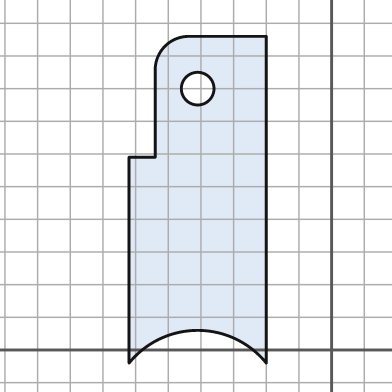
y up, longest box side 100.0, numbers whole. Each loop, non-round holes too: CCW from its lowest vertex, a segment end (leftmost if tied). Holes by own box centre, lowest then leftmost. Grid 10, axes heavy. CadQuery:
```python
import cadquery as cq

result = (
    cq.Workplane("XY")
    .moveTo(-62.0, -4.0)
    .threePointArc((-41.0, 6.0), (-20.0, -4.0))
    .lineTo(-20.0, 96.0)
    .lineTo(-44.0, 96.0)
    .threePointArc((-51.0, 93.0), (-54.0, 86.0))
    .lineTo(-54.0, 59.0)
    .lineTo(-62.0, 59.0)
    .close()
    .moveTo(-41.0, 80.0)
    .circle(5.0)
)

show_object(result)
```